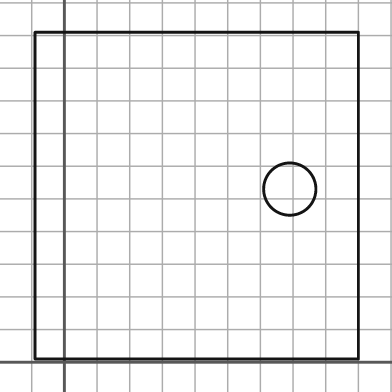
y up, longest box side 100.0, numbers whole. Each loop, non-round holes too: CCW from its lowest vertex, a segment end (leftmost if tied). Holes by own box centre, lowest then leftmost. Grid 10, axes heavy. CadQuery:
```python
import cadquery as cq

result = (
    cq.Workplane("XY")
    .moveTo(-9.0, 1.0)
    .lineTo(90.0, 1.0)
    .lineTo(90.0, 101.0)
    .lineTo(-9.0, 101.0)
    .close()
    .moveTo(69.0, 53.0)
    .circle(8.0)
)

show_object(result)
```